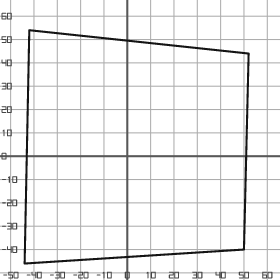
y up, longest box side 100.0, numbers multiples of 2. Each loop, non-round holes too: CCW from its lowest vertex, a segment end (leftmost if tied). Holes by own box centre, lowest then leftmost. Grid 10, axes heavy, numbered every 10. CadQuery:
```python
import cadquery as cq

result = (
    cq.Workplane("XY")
    .moveTo(-44.0, -46.0)
    .lineTo(50.0, -40.0)
    .lineTo(52.0, 44.0)
    .lineTo(-42.0, 54.0)
    .close()
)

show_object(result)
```